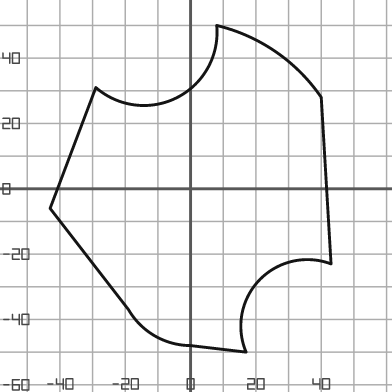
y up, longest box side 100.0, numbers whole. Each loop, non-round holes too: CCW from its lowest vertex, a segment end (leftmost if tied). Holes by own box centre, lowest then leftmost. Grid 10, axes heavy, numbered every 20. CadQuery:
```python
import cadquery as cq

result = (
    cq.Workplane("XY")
    .moveTo(17.0, -50.0)
    .threePointArc((21.0, -28.0), (43.0, -23.0))
    .lineTo(40.0, 28.0)
    .threePointArc((26.0, 42.0), (8.0, 50.0))
    .threePointArc((-4.0, 28.0), (-29.0, 31.0))
    .lineTo(-43.0, -6.0)
    .lineTo(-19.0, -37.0)
    .threePointArc((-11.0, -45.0), (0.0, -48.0))
    .close()
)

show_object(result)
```